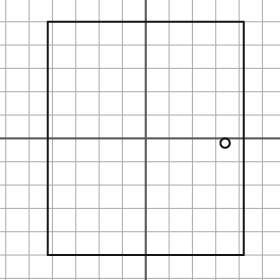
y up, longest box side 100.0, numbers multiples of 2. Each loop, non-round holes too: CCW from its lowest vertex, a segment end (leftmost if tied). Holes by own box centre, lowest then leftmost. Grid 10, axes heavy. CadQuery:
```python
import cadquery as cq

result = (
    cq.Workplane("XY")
    .moveTo(-42.0, -50.0)
    .lineTo(42.0, -50.0)
    .lineTo(42.0, 50.0)
    .lineTo(-42.0, 50.0)
    .close()
    .moveTo(34.0, -2.0)
    .circle(2.0)
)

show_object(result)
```